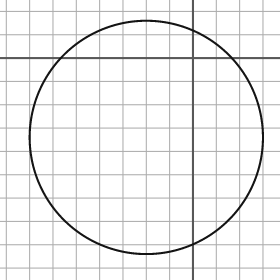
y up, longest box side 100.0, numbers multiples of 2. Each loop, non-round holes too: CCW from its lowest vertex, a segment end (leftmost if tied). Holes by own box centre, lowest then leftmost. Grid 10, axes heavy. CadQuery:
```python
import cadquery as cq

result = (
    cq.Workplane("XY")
    .moveTo(-20.0, -34.0)
    .circle(50.0)
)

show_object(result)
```